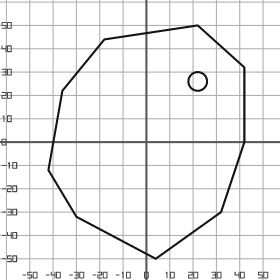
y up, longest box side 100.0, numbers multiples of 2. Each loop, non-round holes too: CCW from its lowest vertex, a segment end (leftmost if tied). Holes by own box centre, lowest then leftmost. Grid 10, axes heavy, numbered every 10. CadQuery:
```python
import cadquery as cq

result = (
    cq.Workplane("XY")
    .moveTo(4.0, -50.0)
    .lineTo(32.0, -30.0)
    .lineTo(42.0, 0.0)
    .lineTo(42.0, 32.0)
    .lineTo(22.0, 50.0)
    .lineTo(-18.0, 44.0)
    .lineTo(-36.0, 22.0)
    .lineTo(-42.0, -12.0)
    .lineTo(-30.0, -32.0)
    .close()
    .moveTo(22.0, 26.0)
    .circle(4.0)
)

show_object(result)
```